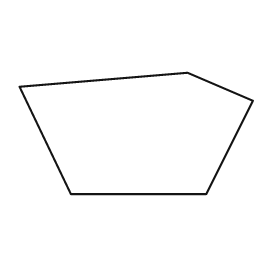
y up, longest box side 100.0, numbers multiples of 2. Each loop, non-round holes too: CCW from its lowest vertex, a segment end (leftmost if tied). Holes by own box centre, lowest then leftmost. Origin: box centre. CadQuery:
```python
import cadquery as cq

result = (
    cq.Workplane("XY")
    .moveTo(-28.0, -26.0)
    .lineTo(30.0, -26.0)
    .lineTo(50.0, 14.0)
    .lineTo(22.0, 26.0)
    .lineTo(-50.0, 20.0)
    .close()
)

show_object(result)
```